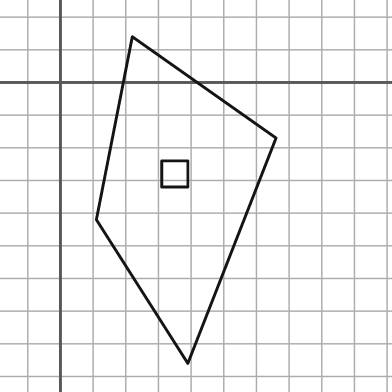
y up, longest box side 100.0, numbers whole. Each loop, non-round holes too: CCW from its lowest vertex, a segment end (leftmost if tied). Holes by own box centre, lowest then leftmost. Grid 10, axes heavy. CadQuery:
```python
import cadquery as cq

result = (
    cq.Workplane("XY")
    .moveTo(39.0, -86.0)
    .lineTo(66.0, -17.0)
    .lineTo(22.0, 14.0)
    .lineTo(11.0, -42.0)
    .close()
    .moveTo(31.0, -32.0)
    .lineTo(39.0, -32.0)
    .lineTo(39.0, -24.0)
    .lineTo(31.0, -24.0)
    .close()
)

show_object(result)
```